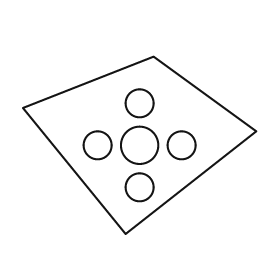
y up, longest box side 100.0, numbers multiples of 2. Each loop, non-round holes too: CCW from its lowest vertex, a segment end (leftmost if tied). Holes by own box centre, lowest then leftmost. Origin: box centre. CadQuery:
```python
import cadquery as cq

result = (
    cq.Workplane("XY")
    .moveTo(-6.0, -38.0)
    .lineTo(50.0, 6.0)
    .lineTo(6.0, 38.0)
    .lineTo(-50.0, 16.0)
    .close()
    .moveTo(0.0, -18.0)
    .circle(6.0)
    .moveTo(-18.0, 0.0)
    .circle(6.0)
    .moveTo(0.0, 0.0)
    .circle(8.0)
    .moveTo(18.0, 0.0)
    .circle(6.0)
    .moveTo(0.0, 18.0)
    .circle(6.0)
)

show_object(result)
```